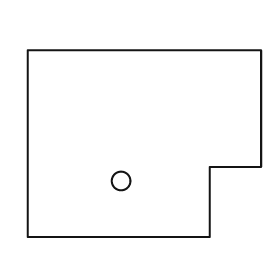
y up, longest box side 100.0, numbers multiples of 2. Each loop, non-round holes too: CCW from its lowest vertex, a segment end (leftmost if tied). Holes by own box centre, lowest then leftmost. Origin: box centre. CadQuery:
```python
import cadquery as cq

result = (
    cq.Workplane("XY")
    .moveTo(-50.0, -40.0)
    .lineTo(28.0, -40.0)
    .lineTo(28.0, -10.0)
    .lineTo(50.0, -10.0)
    .lineTo(50.0, 40.0)
    .lineTo(-50.0, 40.0)
    .close()
    .moveTo(-10.0, -16.0)
    .circle(4.0)
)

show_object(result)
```